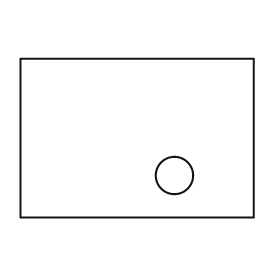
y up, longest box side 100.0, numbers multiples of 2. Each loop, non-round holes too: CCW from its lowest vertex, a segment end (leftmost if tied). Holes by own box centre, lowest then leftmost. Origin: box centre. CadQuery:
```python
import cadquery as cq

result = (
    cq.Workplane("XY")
    .moveTo(-50.0, -34.0)
    .lineTo(50.0, -34.0)
    .lineTo(50.0, 34.0)
    .lineTo(-50.0, 34.0)
    .close()
    .moveTo(16.0, -16.0)
    .circle(8.0)
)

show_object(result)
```